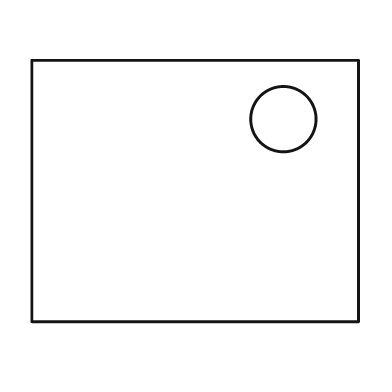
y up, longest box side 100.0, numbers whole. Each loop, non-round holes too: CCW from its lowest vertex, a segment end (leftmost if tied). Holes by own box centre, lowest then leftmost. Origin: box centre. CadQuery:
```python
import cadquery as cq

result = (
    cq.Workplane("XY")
    .moveTo(-50.0, -40.0)
    .lineTo(50.0, -40.0)
    .lineTo(50.0, 40.0)
    .lineTo(-50.0, 40.0)
    .close()
    .moveTo(27.0, 22.0)
    .circle(10.0)
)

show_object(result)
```